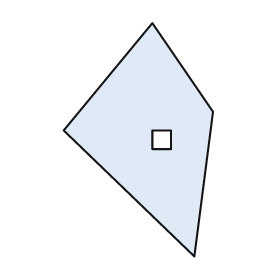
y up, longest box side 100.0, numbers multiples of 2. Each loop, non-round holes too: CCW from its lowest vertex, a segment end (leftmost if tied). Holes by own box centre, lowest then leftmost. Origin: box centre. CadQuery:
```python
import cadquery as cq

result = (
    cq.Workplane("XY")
    .moveTo(24.0, -50.0)
    .lineTo(32.0, 12.0)
    .lineTo(6.0, 50.0)
    .lineTo(-32.0, 4.0)
    .close()
    .moveTo(6.0, -4.0)
    .lineTo(14.0, -4.0)
    .lineTo(14.0, 4.0)
    .lineTo(6.0, 4.0)
    .close()
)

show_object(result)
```